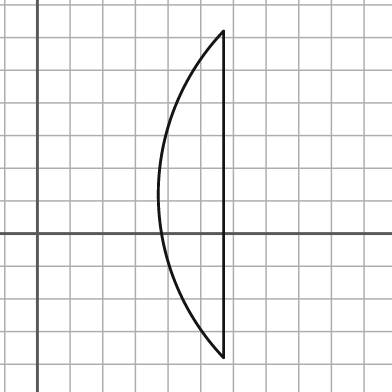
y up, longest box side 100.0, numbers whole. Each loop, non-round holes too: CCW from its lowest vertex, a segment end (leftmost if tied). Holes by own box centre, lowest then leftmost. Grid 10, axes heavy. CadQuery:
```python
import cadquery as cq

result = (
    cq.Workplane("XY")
    .moveTo(57.0, -38.0)
    .lineTo(57.0, 62.0)
    .threePointArc((37.0, 12.0), (57.0, -38.0))
    .close()
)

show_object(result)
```